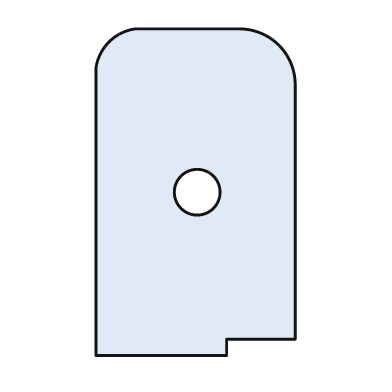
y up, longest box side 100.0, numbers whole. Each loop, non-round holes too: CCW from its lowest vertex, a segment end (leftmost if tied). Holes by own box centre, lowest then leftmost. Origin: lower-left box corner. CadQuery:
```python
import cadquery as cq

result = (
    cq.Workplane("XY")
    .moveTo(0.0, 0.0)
    .lineTo(40.0, 0.0)
    .lineTo(40.0, 5.0)
    .lineTo(61.0, 5.0)
    .lineTo(61.0, 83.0)
    .threePointArc((56.0, 95.0), (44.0, 100.0))
    .lineTo(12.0, 100.0)
    .threePointArc((4.0, 96.0), (0.0, 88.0))
    .close()
    .moveTo(31.0, 50.0)
    .circle(7.0)
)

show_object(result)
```